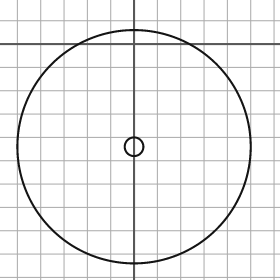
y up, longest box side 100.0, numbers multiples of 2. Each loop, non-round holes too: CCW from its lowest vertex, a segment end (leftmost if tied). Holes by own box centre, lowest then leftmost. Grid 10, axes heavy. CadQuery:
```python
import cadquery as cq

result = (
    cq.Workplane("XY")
    .moveTo(0.0, -44.0)
    .circle(50.0)
    .moveTo(0.0, -44.0)
    .circle(4.0)
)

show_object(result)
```